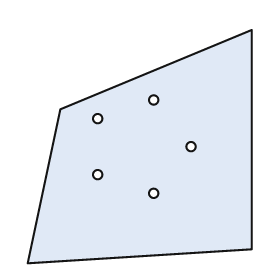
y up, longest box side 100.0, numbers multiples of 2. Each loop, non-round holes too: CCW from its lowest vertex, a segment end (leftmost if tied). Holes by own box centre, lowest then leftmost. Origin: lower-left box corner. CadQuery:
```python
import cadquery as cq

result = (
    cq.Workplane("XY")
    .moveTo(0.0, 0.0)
    .lineTo(96.0, 6.0)
    .lineTo(96.0, 100.0)
    .lineTo(14.0, 66.0)
    .close()
    .moveTo(54.0, 30.0)
    .circle(2.0)
    .moveTo(30.0, 38.0)
    .circle(2.0)
    .moveTo(70.0, 50.0)
    .circle(2.0)
    .moveTo(30.0, 62.0)
    .circle(2.0)
    .moveTo(54.0, 70.0)
    .circle(2.0)
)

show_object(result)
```